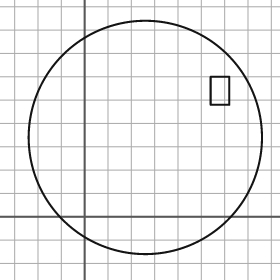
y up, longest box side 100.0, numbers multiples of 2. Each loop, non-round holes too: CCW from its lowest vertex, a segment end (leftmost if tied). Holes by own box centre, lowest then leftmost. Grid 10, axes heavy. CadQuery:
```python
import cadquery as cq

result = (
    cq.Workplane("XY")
    .moveTo(26.0, 34.0)
    .circle(50.0)
    .moveTo(54.0, 48.0)
    .lineTo(62.0, 48.0)
    .lineTo(62.0, 60.0)
    .lineTo(54.0, 60.0)
    .close()
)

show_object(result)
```